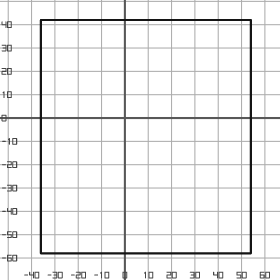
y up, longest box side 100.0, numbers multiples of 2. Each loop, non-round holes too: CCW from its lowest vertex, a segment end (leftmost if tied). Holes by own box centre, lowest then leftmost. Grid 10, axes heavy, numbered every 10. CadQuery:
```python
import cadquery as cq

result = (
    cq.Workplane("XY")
    .moveTo(-36.0, -58.0)
    .lineTo(54.0, -58.0)
    .lineTo(54.0, 42.0)
    .lineTo(-36.0, 42.0)
    .close()
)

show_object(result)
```